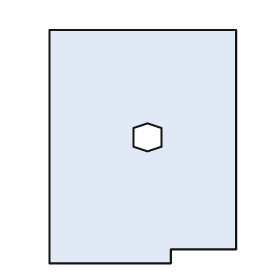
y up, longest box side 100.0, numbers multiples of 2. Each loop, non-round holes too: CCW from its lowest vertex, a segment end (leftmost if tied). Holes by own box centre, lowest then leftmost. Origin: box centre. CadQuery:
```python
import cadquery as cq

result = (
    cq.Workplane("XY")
    .moveTo(-40.0, -50.0)
    .lineTo(12.0, -50.0)
    .lineTo(12.0, -44.0)
    .lineTo(40.0, -44.0)
    .lineTo(40.0, 50.0)
    .lineTo(-40.0, 50.0)
    .close()
    .moveTo(2.0, -2.0)
    .lineTo(8.0, 0.0)
    .lineTo(8.0, 8.0)
    .lineTo(2.0, 10.0)
    .lineTo(-4.0, 8.0)
    .lineTo(-4.0, 0.0)
    .close()
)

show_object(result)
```